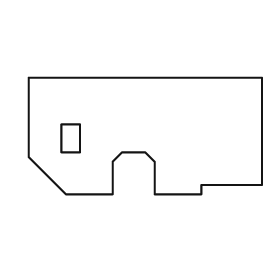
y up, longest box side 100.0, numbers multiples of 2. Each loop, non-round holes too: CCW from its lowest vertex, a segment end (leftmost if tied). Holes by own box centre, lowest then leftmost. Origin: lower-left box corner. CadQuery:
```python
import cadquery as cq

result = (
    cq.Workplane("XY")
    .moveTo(16.0, 0.0)
    .lineTo(36.0, 0.0)
    .lineTo(36.0, 14.0)
    .lineTo(40.0, 18.0)
    .lineTo(50.0, 18.0)
    .lineTo(54.0, 14.0)
    .lineTo(54.0, 0.0)
    .lineTo(74.0, 0.0)
    .lineTo(74.0, 4.0)
    .lineTo(100.0, 4.0)
    .lineTo(100.0, 50.0)
    .lineTo(0.0, 50.0)
    .lineTo(0.0, 16.0)
    .close()
    .moveTo(14.0, 18.0)
    .lineTo(22.0, 18.0)
    .lineTo(22.0, 30.0)
    .lineTo(14.0, 30.0)
    .close()
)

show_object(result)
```